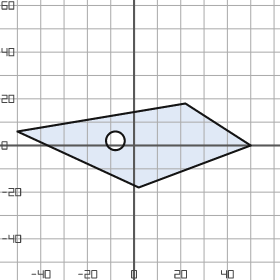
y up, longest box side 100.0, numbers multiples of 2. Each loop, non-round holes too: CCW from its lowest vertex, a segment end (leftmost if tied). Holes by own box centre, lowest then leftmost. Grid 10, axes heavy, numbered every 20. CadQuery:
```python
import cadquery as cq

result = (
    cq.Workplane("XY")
    .moveTo(2.0, -18.0)
    .lineTo(50.0, 0.0)
    .lineTo(22.0, 18.0)
    .lineTo(-50.0, 6.0)
    .close()
    .moveTo(-8.0, 2.0)
    .circle(4.0)
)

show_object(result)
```